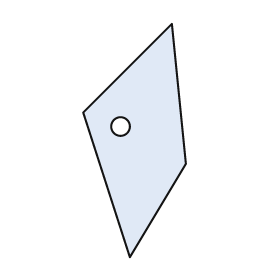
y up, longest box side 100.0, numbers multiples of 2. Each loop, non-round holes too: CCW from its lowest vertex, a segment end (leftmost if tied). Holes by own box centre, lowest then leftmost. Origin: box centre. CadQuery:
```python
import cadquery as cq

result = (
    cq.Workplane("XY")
    .moveTo(-2.0, -50.0)
    .lineTo(22.0, -10.0)
    .lineTo(16.0, 50.0)
    .lineTo(-22.0, 12.0)
    .close()
    .moveTo(-6.0, 6.0)
    .circle(4.0)
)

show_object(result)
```